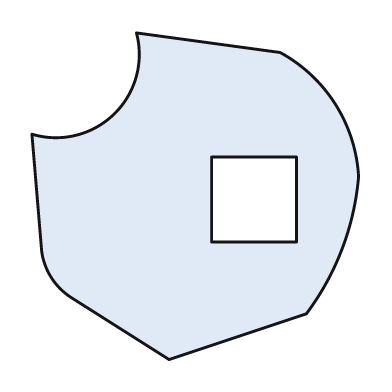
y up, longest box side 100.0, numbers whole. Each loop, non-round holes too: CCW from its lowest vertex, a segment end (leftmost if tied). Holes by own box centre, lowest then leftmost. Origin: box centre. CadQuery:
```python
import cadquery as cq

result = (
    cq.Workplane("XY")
    .moveTo(-8.0, -50.0)
    .lineTo(34.0, -36.0)
    .threePointArc((45.0, -16.0), (50.0, 6.0))
    .threePointArc((43.0, 28.0), (26.0, 44.0))
    .lineTo(-18.0, 50.0)
    .threePointArc((-25.0, 25.0), (-50.0, 19.0))
    .lineTo(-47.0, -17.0)
    .threePointArc((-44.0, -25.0), (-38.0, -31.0))
    .close()
    .moveTo(5.0, -14.0)
    .lineTo(31.0, -14.0)
    .lineTo(31.0, 12.0)
    .lineTo(5.0, 12.0)
    .close()
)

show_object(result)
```